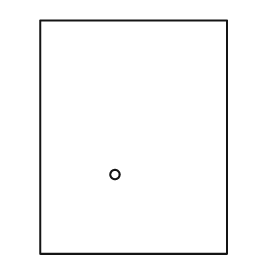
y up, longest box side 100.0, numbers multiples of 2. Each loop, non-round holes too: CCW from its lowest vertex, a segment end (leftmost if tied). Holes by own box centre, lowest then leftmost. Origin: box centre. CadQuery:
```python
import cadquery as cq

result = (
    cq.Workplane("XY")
    .moveTo(-40.0, -50.0)
    .lineTo(40.0, -50.0)
    .lineTo(40.0, 50.0)
    .lineTo(-40.0, 50.0)
    .close()
    .moveTo(-8.0, -16.0)
    .circle(2.0)
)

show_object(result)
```